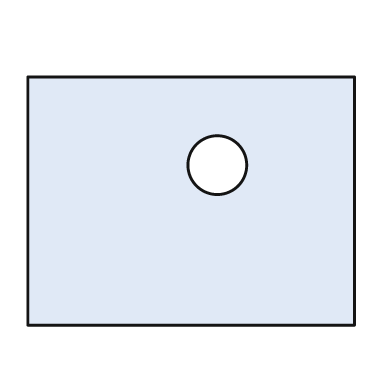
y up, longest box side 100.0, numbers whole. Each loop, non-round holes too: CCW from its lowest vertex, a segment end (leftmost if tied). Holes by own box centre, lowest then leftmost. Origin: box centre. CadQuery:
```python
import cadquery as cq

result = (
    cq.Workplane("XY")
    .moveTo(-50.0, -38.0)
    .lineTo(50.0, -38.0)
    .lineTo(50.0, 38.0)
    .lineTo(-50.0, 38.0)
    .close()
    .moveTo(8.0, 11.0)
    .circle(9.0)
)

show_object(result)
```